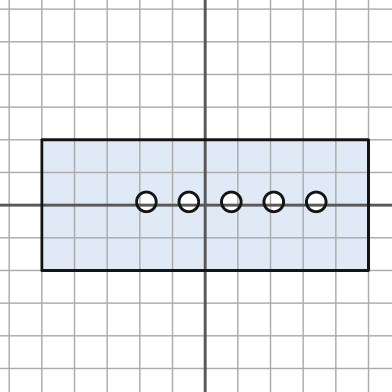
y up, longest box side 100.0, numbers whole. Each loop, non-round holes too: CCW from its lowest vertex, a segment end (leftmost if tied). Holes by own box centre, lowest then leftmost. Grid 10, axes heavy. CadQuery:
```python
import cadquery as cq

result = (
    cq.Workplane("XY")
    .moveTo(-50.0, -20.0)
    .lineTo(50.0, -20.0)
    .lineTo(50.0, 20.0)
    .lineTo(-50.0, 20.0)
    .close()
    .moveTo(-18.0, 1.0)
    .circle(3.0)
    .moveTo(-5.0, 1.0)
    .circle(3.0)
    .moveTo(8.0, 1.0)
    .circle(3.0)
    .moveTo(21.0, 1.0)
    .circle(3.0)
    .moveTo(34.0, 1.0)
    .circle(3.0)
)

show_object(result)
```